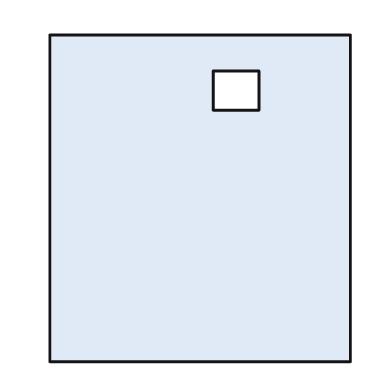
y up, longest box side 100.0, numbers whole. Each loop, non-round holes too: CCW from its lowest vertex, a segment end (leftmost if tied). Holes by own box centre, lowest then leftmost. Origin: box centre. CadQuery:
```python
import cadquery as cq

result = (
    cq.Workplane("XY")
    .moveTo(-46.0, -50.0)
    .lineTo(46.0, -50.0)
    .lineTo(46.0, 50.0)
    .lineTo(-46.0, 50.0)
    .close()
    .moveTo(4.0, 27.0)
    .lineTo(18.0, 27.0)
    .lineTo(18.0, 39.0)
    .lineTo(4.0, 39.0)
    .close()
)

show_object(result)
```